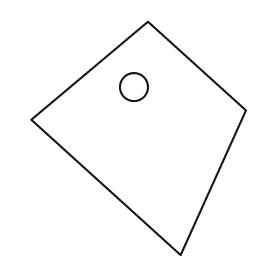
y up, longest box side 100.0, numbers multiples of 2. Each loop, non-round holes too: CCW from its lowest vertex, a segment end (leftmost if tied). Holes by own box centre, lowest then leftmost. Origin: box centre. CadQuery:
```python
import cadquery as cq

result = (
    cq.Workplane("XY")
    .moveTo(18.0, -50.0)
    .lineTo(46.0, 12.0)
    .lineTo(4.0, 50.0)
    .lineTo(-46.0, 8.0)
    .close()
    .moveTo(-2.0, 22.0)
    .circle(6.0)
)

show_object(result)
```